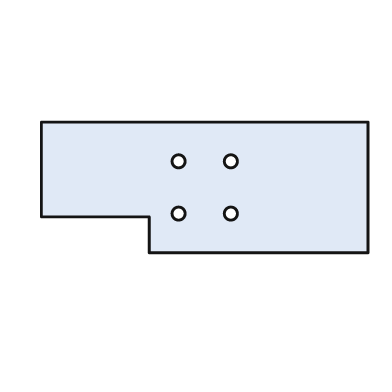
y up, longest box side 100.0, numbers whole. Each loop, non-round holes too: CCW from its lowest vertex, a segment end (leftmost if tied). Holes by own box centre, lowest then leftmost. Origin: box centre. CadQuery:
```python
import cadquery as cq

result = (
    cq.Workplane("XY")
    .moveTo(-17.0, -20.0)
    .lineTo(50.0, -20.0)
    .lineTo(50.0, 20.0)
    .lineTo(-50.0, 20.0)
    .lineTo(-50.0, -9.0)
    .lineTo(-17.0, -9.0)
    .close()
    .moveTo(-8.0, -8.0)
    .circle(2.0)
    .moveTo(8.0, -8.0)
    .circle(2.0)
    .moveTo(-8.0, 8.0)
    .circle(2.0)
    .moveTo(8.0, 8.0)
    .circle(2.0)
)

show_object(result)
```